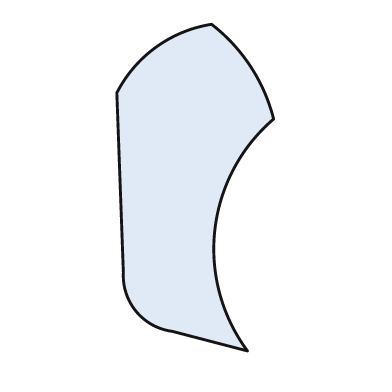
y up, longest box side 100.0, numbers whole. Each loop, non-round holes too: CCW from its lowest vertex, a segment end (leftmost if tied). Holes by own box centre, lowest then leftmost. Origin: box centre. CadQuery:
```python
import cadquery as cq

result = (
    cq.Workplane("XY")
    .moveTo(16.0, -50.0)
    .threePointArc((6.0, -13.0), (24.0, 21.0))
    .threePointArc((17.0, 37.0), (5.0, 50.0))
    .threePointArc((-12.0, 43.0), (-24.0, 29.0))
    .lineTo(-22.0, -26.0)
    .threePointArc((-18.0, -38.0), (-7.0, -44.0))
    .close()
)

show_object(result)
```